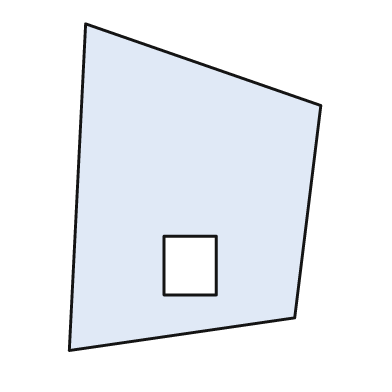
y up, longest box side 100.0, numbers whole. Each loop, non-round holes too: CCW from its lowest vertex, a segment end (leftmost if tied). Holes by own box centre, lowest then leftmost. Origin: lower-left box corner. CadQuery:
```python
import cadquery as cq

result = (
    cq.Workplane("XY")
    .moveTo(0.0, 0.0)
    .lineTo(69.0, 10.0)
    .lineTo(77.0, 75.0)
    .lineTo(5.0, 100.0)
    .close()
    .moveTo(29.0, 17.0)
    .lineTo(45.0, 17.0)
    .lineTo(45.0, 35.0)
    .lineTo(29.0, 35.0)
    .close()
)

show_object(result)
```